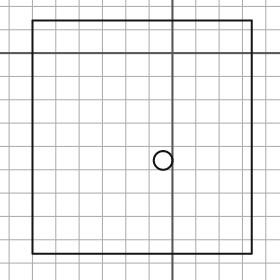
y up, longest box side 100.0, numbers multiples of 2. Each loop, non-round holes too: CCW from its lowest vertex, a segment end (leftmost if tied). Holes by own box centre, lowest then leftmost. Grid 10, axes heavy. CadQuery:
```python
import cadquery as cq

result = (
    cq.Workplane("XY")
    .moveTo(-60.0, -86.0)
    .lineTo(34.0, -86.0)
    .lineTo(34.0, 14.0)
    .lineTo(-60.0, 14.0)
    .close()
    .moveTo(-4.0, -46.0)
    .circle(4.0)
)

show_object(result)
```